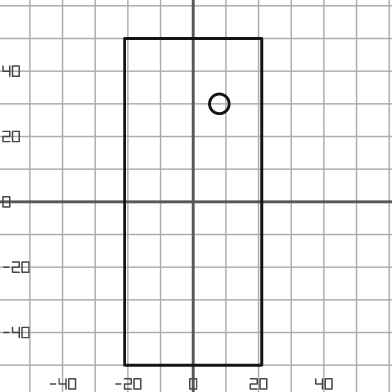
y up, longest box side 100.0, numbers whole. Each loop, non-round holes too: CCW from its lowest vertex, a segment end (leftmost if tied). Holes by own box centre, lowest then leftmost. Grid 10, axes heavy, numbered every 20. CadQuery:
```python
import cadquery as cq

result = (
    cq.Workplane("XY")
    .moveTo(-21.0, -50.0)
    .lineTo(21.0, -50.0)
    .lineTo(21.0, 50.0)
    .lineTo(-21.0, 50.0)
    .close()
    .moveTo(8.0, 30.0)
    .circle(3.0)
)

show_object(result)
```